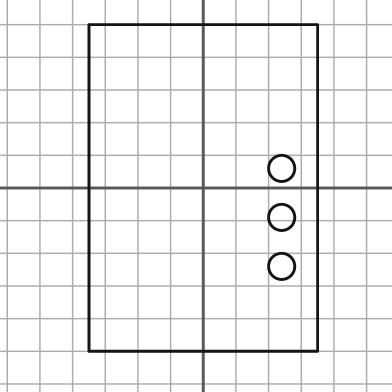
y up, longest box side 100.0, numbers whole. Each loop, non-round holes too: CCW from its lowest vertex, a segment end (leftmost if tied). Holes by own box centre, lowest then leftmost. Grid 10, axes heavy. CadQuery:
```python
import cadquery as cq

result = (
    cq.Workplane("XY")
    .moveTo(-35.0, -50.0)
    .lineTo(35.0, -50.0)
    .lineTo(35.0, 50.0)
    .lineTo(-35.0, 50.0)
    .close()
    .moveTo(24.0, -24.0)
    .circle(4.0)
    .moveTo(24.0, -9.0)
    .circle(4.0)
    .moveTo(24.0, 6.0)
    .circle(4.0)
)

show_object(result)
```